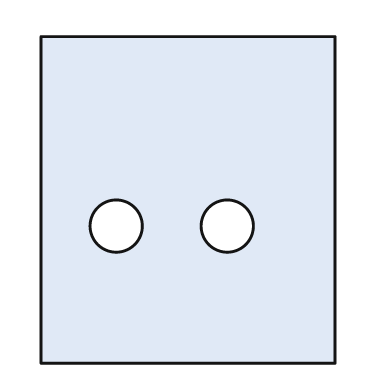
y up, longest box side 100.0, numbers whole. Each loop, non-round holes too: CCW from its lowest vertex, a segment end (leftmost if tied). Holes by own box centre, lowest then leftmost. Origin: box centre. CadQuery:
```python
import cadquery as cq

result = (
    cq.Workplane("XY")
    .moveTo(-45.0, -50.0)
    .lineTo(45.0, -50.0)
    .lineTo(45.0, 50.0)
    .lineTo(-45.0, 50.0)
    .close()
    .moveTo(-22.0, -8.0)
    .circle(8.0)
    .moveTo(12.0, -8.0)
    .circle(8.0)
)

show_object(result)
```